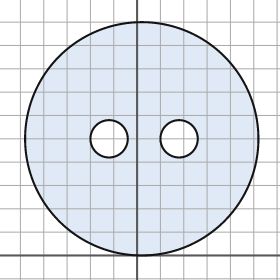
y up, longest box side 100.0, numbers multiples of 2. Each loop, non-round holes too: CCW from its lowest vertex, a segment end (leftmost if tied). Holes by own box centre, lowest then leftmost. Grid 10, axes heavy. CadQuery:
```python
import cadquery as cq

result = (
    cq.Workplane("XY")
    .moveTo(2.0, 50.0)
    .circle(50.0)
    .moveTo(-12.0, 50.0)
    .circle(8.0)
    .moveTo(18.0, 50.0)
    .circle(8.0)
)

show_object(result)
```